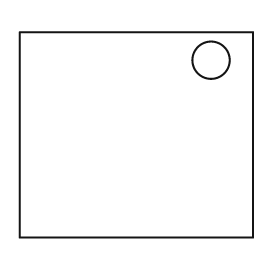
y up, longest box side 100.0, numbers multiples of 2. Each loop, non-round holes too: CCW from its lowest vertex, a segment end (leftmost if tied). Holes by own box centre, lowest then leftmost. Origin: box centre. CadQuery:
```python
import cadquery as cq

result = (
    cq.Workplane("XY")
    .moveTo(-50.0, -44.0)
    .lineTo(50.0, -44.0)
    .lineTo(50.0, 44.0)
    .lineTo(-50.0, 44.0)
    .close()
    .moveTo(32.0, 32.0)
    .circle(8.0)
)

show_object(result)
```